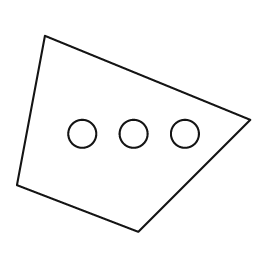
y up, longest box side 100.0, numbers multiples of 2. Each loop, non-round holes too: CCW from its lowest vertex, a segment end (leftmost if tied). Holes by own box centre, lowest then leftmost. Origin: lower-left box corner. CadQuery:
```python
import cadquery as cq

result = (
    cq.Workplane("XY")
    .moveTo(52.0, 0.0)
    .lineTo(100.0, 48.0)
    .lineTo(12.0, 84.0)
    .lineTo(0.0, 20.0)
    .close()
    .moveTo(28.0, 42.0)
    .circle(6.0)
    .moveTo(50.0, 42.0)
    .circle(6.0)
    .moveTo(72.0, 42.0)
    .circle(6.0)
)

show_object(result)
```